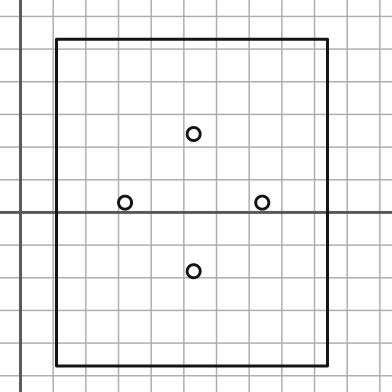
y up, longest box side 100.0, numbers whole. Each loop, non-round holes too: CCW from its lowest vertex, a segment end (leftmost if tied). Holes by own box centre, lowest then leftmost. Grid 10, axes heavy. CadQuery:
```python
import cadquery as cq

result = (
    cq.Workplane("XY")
    .moveTo(11.0, -47.0)
    .lineTo(94.0, -47.0)
    .lineTo(94.0, 53.0)
    .lineTo(11.0, 53.0)
    .close()
    .moveTo(53.0, -18.0)
    .circle(2.0)
    .moveTo(32.0, 3.0)
    .circle(2.0)
    .moveTo(74.0, 3.0)
    .circle(2.0)
    .moveTo(53.0, 24.0)
    .circle(2.0)
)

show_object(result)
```